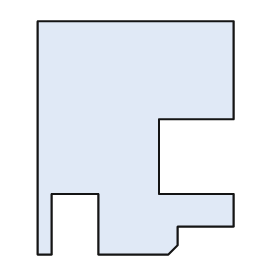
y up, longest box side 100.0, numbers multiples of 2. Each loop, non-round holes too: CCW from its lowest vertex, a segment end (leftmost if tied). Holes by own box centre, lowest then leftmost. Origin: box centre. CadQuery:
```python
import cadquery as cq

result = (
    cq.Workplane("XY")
    .moveTo(-42.0, -50.0)
    .lineTo(-36.0, -50.0)
    .lineTo(-36.0, -24.0)
    .lineTo(-16.0, -24.0)
    .lineTo(-16.0, -50.0)
    .lineTo(14.0, -50.0)
    .lineTo(18.0, -46.0)
    .lineTo(18.0, -38.0)
    .lineTo(42.0, -38.0)
    .lineTo(42.0, -24.0)
    .lineTo(10.0, -24.0)
    .lineTo(10.0, 8.0)
    .lineTo(42.0, 8.0)
    .lineTo(42.0, 50.0)
    .lineTo(-42.0, 50.0)
    .close()
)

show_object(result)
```